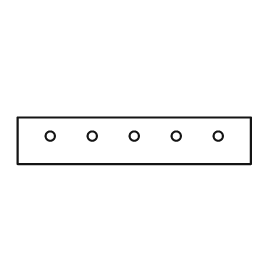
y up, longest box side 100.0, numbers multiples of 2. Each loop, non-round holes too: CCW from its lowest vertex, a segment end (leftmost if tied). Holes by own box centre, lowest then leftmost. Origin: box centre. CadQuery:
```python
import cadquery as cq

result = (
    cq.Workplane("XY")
    .moveTo(-50.0, -10.0)
    .lineTo(50.0, -10.0)
    .lineTo(50.0, 10.0)
    .lineTo(-50.0, 10.0)
    .close()
    .moveTo(-36.0, 2.0)
    .circle(2.0)
    .moveTo(-18.0, 2.0)
    .circle(2.0)
    .moveTo(0.0, 2.0)
    .circle(2.0)
    .moveTo(18.0, 2.0)
    .circle(2.0)
    .moveTo(36.0, 2.0)
    .circle(2.0)
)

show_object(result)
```